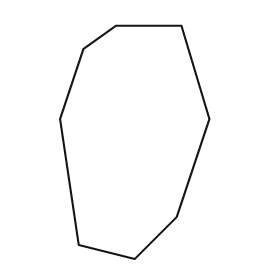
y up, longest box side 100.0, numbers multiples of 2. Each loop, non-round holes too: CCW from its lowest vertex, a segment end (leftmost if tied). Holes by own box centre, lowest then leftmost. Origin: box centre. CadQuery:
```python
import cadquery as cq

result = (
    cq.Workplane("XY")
    .moveTo(0.0, -50.0)
    .lineTo(18.0, -32.0)
    .lineTo(32.0, 10.0)
    .lineTo(20.0, 50.0)
    .lineTo(-8.0, 50.0)
    .lineTo(-22.0, 40.0)
    .lineTo(-32.0, 10.0)
    .lineTo(-24.0, -44.0)
    .close()
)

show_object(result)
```